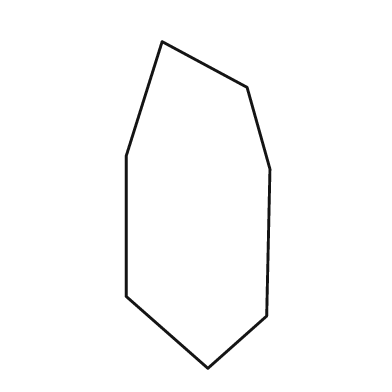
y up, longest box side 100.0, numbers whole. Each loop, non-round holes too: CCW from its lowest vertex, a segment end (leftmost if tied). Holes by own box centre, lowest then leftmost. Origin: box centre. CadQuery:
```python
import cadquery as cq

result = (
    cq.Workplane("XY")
    .moveTo(3.0, -50.0)
    .lineTo(21.0, -34.0)
    .lineTo(22.0, 11.0)
    .lineTo(15.0, 36.0)
    .lineTo(-11.0, 50.0)
    .lineTo(-22.0, 15.0)
    .lineTo(-22.0, -28.0)
    .close()
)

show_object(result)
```